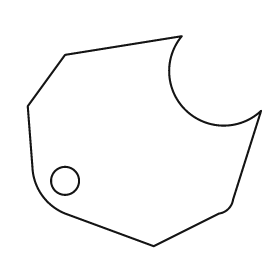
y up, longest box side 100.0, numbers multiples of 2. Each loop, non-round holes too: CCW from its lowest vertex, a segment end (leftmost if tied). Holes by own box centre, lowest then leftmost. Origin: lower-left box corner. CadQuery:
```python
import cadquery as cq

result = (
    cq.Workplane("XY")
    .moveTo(54.0, 0.0)
    .lineTo(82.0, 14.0)
    .threePointArc((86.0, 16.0), (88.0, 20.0))
    .lineTo(100.0, 58.0)
    .threePointArc((68.0, 58.0), (66.0, 90.0))
    .lineTo(16.0, 82.0)
    .lineTo(0.0, 60.0)
    .lineTo(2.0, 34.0)
    .threePointArc((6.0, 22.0), (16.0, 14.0))
    .close()
    .moveTo(16.0, 28.0)
    .circle(6.0)
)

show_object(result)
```